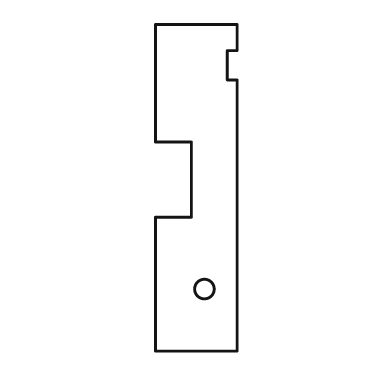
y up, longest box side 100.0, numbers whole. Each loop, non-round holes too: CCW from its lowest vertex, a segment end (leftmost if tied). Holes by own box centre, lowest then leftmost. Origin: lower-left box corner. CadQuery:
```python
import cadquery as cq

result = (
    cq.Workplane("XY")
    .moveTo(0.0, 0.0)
    .lineTo(25.0, 0.0)
    .lineTo(25.0, 83.0)
    .lineTo(22.0, 83.0)
    .lineTo(22.0, 92.0)
    .lineTo(25.0, 92.0)
    .lineTo(25.0, 100.0)
    .lineTo(0.0, 100.0)
    .lineTo(0.0, 64.0)
    .lineTo(11.0, 64.0)
    .lineTo(11.0, 41.0)
    .lineTo(0.0, 41.0)
    .close()
    .moveTo(15.0, 19.0)
    .circle(3.0)
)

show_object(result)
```